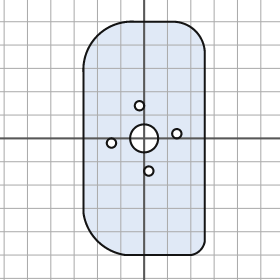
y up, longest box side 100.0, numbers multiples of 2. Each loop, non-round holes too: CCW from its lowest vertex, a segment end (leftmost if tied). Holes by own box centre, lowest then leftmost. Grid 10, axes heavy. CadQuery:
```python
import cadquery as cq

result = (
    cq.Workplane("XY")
    .moveTo(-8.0, -50.0)
    .lineTo(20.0, -50.0)
    .threePointArc((24.0, -48.0), (26.0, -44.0))
    .lineTo(26.0, 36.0)
    .threePointArc((22.0, 46.0), (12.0, 50.0))
    .lineTo(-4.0, 50.0)
    .threePointArc((-20.0, 44.0), (-26.0, 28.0))
    .lineTo(-26.0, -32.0)
    .threePointArc((-20.0, -44.0), (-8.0, -50.0))
    .close()
    .moveTo(2.0, -14.0)
    .circle(2.0)
    .moveTo(-14.0, -2.0)
    .circle(2.0)
    .moveTo(0.0, 0.0)
    .circle(6.0)
    .moveTo(14.0, 2.0)
    .circle(2.0)
    .moveTo(-2.0, 14.0)
    .circle(2.0)
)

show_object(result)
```